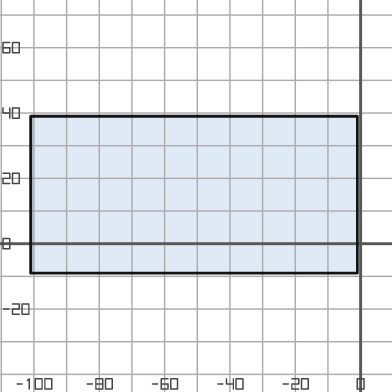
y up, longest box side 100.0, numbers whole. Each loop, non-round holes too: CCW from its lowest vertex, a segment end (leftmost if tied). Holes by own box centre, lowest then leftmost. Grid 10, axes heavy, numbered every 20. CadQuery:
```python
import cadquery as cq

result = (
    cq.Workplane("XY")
    .moveTo(-101.0, -9.0)
    .lineTo(-1.0, -9.0)
    .lineTo(-1.0, 39.0)
    .lineTo(-101.0, 39.0)
    .close()
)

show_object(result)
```